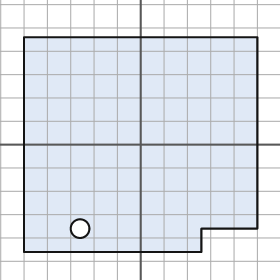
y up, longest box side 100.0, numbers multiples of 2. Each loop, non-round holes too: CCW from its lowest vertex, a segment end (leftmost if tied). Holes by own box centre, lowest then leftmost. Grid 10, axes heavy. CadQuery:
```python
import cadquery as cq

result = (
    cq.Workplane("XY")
    .moveTo(-50.0, -46.0)
    .lineTo(26.0, -46.0)
    .lineTo(26.0, -36.0)
    .lineTo(50.0, -36.0)
    .lineTo(50.0, 46.0)
    .lineTo(-50.0, 46.0)
    .close()
    .moveTo(-26.0, -36.0)
    .circle(4.0)
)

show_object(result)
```